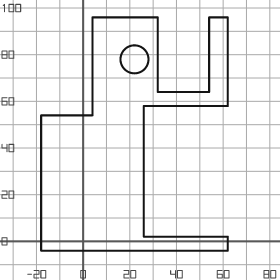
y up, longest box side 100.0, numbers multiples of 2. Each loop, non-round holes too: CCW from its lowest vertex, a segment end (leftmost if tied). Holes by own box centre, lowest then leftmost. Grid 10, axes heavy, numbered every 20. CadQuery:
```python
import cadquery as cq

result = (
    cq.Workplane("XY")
    .moveTo(-18.0, -4.0)
    .lineTo(62.0, -4.0)
    .lineTo(62.0, 2.0)
    .lineTo(26.0, 2.0)
    .lineTo(26.0, 58.0)
    .lineTo(62.0, 58.0)
    .lineTo(62.0, 96.0)
    .lineTo(54.0, 96.0)
    .lineTo(54.0, 64.0)
    .lineTo(32.0, 64.0)
    .lineTo(32.0, 96.0)
    .lineTo(4.0, 96.0)
    .lineTo(4.0, 54.0)
    .lineTo(-18.0, 54.0)
    .close()
    .moveTo(22.0, 78.0)
    .circle(6.0)
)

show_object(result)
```